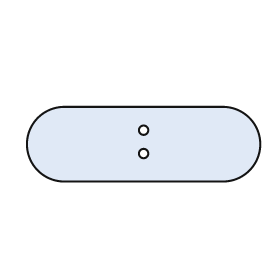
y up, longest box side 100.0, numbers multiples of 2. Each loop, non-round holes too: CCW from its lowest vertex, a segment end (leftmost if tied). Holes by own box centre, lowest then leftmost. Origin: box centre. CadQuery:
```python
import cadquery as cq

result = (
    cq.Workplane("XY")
    .moveTo(-34.0, -16.0)
    .lineTo(34.0, -16.0)
    .threePointArc((50.0, 0.0), (34.0, 16.0))
    .lineTo(-34.0, 16.0)
    .threePointArc((-50.0, 0.0), (-34.0, -16.0))
    .close()
    .moveTo(0.0, -4.0)
    .circle(2.0)
    .moveTo(0.0, 6.0)
    .circle(2.0)
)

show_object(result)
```